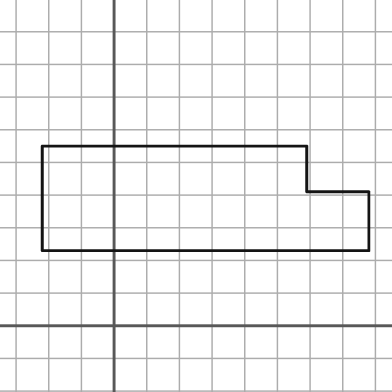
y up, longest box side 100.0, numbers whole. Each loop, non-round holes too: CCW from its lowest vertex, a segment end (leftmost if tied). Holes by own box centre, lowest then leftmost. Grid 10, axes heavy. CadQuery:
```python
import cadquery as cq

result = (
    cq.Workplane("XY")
    .moveTo(-22.0, 23.0)
    .lineTo(78.0, 23.0)
    .lineTo(78.0, 41.0)
    .lineTo(59.0, 41.0)
    .lineTo(59.0, 55.0)
    .lineTo(-22.0, 55.0)
    .close()
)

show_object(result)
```